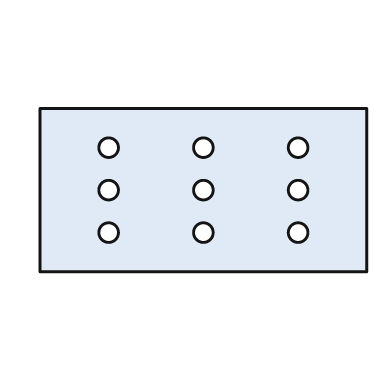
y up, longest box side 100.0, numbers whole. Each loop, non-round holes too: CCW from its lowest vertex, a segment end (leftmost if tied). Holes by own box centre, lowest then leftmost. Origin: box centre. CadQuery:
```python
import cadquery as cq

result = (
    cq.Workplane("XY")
    .moveTo(-50.0, -25.0)
    .lineTo(50.0, -25.0)
    .lineTo(50.0, 25.0)
    .lineTo(-50.0, 25.0)
    .close()
    .moveTo(-29.0, -13.0)
    .circle(3.0)
    .moveTo(0.0, -13.0)
    .circle(3.0)
    .moveTo(29.0, -13.0)
    .circle(3.0)
    .moveTo(-29.0, 0.0)
    .circle(3.0)
    .moveTo(0.0, 0.0)
    .circle(3.0)
    .moveTo(29.0, 0.0)
    .circle(3.0)
    .moveTo(-29.0, 13.0)
    .circle(3.0)
    .moveTo(0.0, 13.0)
    .circle(3.0)
    .moveTo(29.0, 13.0)
    .circle(3.0)
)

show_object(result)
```